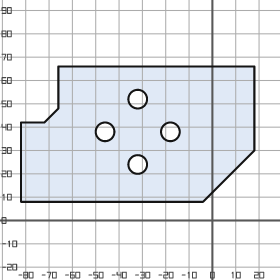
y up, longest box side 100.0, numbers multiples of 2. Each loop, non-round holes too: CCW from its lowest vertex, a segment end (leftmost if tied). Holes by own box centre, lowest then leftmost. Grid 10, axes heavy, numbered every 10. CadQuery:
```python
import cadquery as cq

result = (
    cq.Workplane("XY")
    .moveTo(-82.0, 8.0)
    .lineTo(-4.0, 8.0)
    .lineTo(18.0, 30.0)
    .lineTo(18.0, 66.0)
    .lineTo(-66.0, 66.0)
    .lineTo(-66.0, 48.0)
    .lineTo(-72.0, 42.0)
    .lineTo(-82.0, 42.0)
    .close()
    .moveTo(-32.0, 24.0)
    .circle(4.0)
    .moveTo(-46.0, 38.0)
    .circle(4.0)
    .moveTo(-18.0, 38.0)
    .circle(4.0)
    .moveTo(-32.0, 52.0)
    .circle(4.0)
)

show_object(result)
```